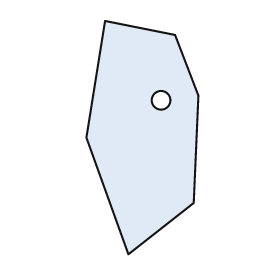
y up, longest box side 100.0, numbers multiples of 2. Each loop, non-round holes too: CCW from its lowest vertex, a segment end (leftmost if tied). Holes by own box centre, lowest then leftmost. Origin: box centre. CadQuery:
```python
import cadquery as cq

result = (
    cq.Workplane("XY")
    .moveTo(-6.0, -50.0)
    .lineTo(22.0, -28.0)
    .lineTo(24.0, 18.0)
    .lineTo(14.0, 44.0)
    .lineTo(-16.0, 50.0)
    .lineTo(-24.0, 0.0)
    .close()
    .moveTo(8.0, 16.0)
    .circle(4.0)
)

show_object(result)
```